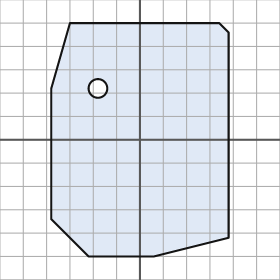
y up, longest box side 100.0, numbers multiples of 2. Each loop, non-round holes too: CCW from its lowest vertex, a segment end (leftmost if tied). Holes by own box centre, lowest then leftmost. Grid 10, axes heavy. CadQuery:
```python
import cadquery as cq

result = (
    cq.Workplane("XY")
    .moveTo(-22.0, -50.0)
    .lineTo(6.0, -50.0)
    .lineTo(38.0, -42.0)
    .lineTo(38.0, 46.0)
    .lineTo(34.0, 50.0)
    .lineTo(-30.0, 50.0)
    .lineTo(-38.0, 22.0)
    .lineTo(-38.0, -34.0)
    .close()
    .moveTo(-18.0, 22.0)
    .circle(4.0)
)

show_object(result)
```